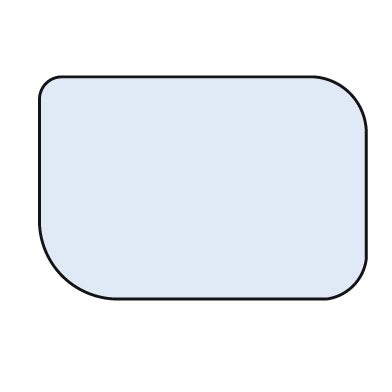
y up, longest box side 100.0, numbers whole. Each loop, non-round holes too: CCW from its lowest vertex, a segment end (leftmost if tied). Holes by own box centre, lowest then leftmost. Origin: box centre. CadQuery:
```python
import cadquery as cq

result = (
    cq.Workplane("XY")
    .moveTo(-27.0, -34.0)
    .lineTo(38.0, -34.0)
    .threePointArc((46.0, -30.0), (50.0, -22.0))
    .lineTo(50.0, 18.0)
    .threePointArc((45.0, 29.0), (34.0, 34.0))
    .lineTo(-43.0, 34.0)
    .threePointArc((-48.0, 32.0), (-50.0, 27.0))
    .lineTo(-50.0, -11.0)
    .threePointArc((-43.0, -27.0), (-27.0, -34.0))
    .close()
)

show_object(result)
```